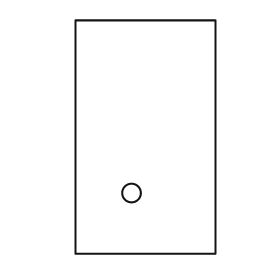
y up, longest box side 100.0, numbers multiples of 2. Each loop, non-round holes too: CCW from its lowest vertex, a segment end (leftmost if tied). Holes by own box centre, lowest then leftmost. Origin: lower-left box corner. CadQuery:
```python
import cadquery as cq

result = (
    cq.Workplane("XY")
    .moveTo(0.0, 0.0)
    .lineTo(60.0, 0.0)
    .lineTo(60.0, 100.0)
    .lineTo(0.0, 100.0)
    .close()
    .moveTo(24.0, 26.0)
    .circle(4.0)
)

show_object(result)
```